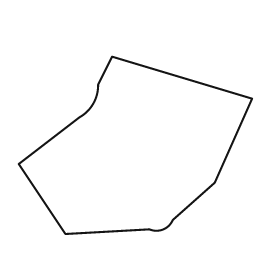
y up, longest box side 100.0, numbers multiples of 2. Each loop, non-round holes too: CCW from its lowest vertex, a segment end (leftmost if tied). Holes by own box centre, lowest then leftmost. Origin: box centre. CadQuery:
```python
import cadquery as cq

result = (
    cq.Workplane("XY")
    .moveTo(-30.0, -38.0)
    .lineTo(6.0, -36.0)
    .threePointArc((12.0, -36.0), (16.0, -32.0))
    .lineTo(34.0, -16.0)
    .lineTo(50.0, 20.0)
    .lineTo(-10.0, 38.0)
    .lineTo(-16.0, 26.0)
    .threePointArc((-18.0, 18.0), (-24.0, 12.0))
    .lineTo(-50.0, -8.0)
    .close()
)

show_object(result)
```